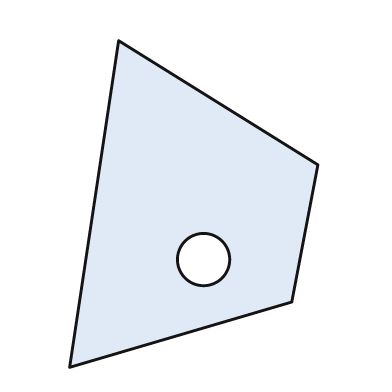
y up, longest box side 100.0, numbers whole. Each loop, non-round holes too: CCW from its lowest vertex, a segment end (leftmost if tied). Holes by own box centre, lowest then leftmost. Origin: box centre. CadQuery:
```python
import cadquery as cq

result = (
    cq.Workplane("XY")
    .moveTo(-38.0, -50.0)
    .lineTo(30.0, -30.0)
    .lineTo(38.0, 12.0)
    .lineTo(-23.0, 50.0)
    .close()
    .moveTo(3.0, -17.0)
    .circle(8.0)
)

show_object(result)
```